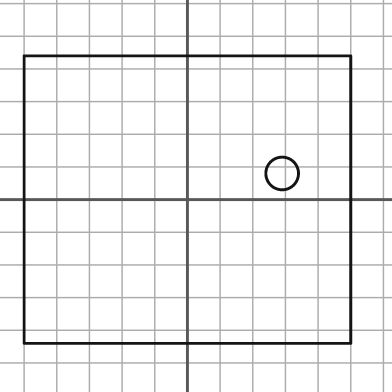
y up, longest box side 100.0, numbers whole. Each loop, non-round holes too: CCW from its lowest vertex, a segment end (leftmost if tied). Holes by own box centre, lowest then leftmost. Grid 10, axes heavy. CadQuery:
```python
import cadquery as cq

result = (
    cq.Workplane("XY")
    .moveTo(-50.0, -44.0)
    .lineTo(50.0, -44.0)
    .lineTo(50.0, 44.0)
    .lineTo(-50.0, 44.0)
    .close()
    .moveTo(29.0, 8.0)
    .circle(5.0)
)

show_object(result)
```